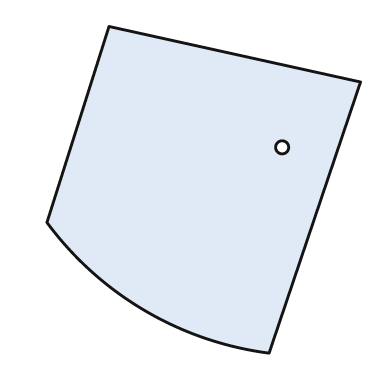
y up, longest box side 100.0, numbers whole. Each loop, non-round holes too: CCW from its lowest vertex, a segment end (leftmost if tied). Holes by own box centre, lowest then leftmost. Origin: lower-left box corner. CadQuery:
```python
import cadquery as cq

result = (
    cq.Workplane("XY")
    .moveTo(68.0, 0.0)
    .lineTo(96.0, 83.0)
    .lineTo(19.0, 100.0)
    .lineTo(0.0, 40.0)
    .threePointArc((30.0, 13.0), (68.0, 0.0))
    .close()
    .moveTo(72.0, 63.0)
    .circle(2.0)
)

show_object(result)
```